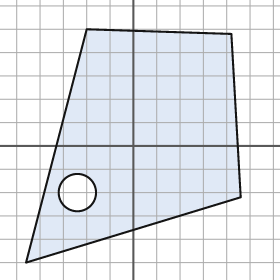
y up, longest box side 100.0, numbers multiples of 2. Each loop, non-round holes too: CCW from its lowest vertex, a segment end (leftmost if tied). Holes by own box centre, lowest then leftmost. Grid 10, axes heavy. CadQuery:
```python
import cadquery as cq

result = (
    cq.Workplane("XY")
    .moveTo(-46.0, -50.0)
    .lineTo(46.0, -22.0)
    .lineTo(42.0, 48.0)
    .lineTo(-20.0, 50.0)
    .close()
    .moveTo(-24.0, -20.0)
    .circle(8.0)
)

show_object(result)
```